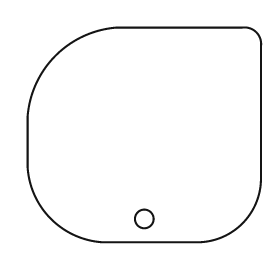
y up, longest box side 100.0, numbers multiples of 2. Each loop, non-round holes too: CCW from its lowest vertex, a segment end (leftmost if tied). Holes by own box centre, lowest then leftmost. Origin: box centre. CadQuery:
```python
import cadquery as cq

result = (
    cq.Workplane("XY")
    .moveTo(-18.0, -46.0)
    .lineTo(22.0, -46.0)
    .threePointArc((42.0, -38.0), (50.0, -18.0))
    .lineTo(50.0, 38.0)
    .threePointArc((48.0, 44.0), (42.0, 46.0))
    .lineTo(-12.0, 46.0)
    .threePointArc((-38.0, 34.0), (-50.0, 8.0))
    .lineTo(-50.0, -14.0)
    .threePointArc((-40.0, -36.0), (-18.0, -46.0))
    .close()
    .moveTo(0.0, -36.0)
    .circle(4.0)
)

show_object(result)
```